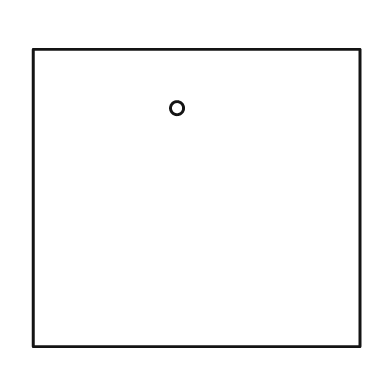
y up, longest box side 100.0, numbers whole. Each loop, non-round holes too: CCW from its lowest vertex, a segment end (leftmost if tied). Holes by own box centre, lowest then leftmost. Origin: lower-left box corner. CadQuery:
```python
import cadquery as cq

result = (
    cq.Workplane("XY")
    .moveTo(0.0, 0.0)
    .lineTo(100.0, 0.0)
    .lineTo(100.0, 91.0)
    .lineTo(0.0, 91.0)
    .close()
    .moveTo(44.0, 73.0)
    .circle(2.0)
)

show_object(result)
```